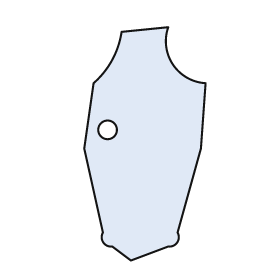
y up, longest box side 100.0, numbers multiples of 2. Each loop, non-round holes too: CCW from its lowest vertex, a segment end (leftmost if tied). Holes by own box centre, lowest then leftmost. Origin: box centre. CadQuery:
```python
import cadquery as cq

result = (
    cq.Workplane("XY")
    .moveTo(-6.0, -50.0)
    .lineTo(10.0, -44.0)
    .threePointArc((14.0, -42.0), (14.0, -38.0))
    .lineTo(24.0, -2.0)
    .lineTo(26.0, 26.0)
    .threePointArc((12.0, 34.0), (10.0, 50.0))
    .lineTo(-10.0, 48.0)
    .threePointArc((-14.0, 36.0), (-22.0, 26.0))
    .lineTo(-26.0, -2.0)
    .lineTo(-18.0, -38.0)
    .threePointArc((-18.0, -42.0), (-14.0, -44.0))
    .close()
    .moveTo(-16.0, 6.0)
    .circle(4.0)
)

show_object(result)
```